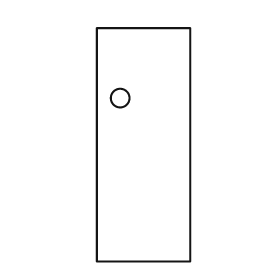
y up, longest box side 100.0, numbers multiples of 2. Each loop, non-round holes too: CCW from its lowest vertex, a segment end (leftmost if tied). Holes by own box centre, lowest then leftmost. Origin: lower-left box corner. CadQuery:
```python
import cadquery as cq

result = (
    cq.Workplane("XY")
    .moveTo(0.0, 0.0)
    .lineTo(40.0, 0.0)
    .lineTo(40.0, 100.0)
    .lineTo(0.0, 100.0)
    .close()
    .moveTo(10.0, 70.0)
    .circle(4.0)
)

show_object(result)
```